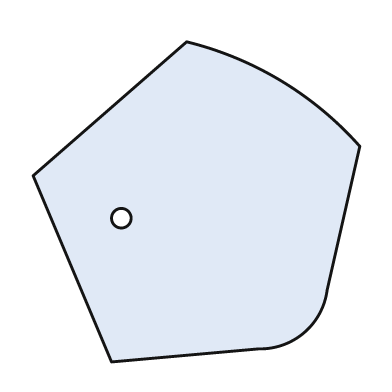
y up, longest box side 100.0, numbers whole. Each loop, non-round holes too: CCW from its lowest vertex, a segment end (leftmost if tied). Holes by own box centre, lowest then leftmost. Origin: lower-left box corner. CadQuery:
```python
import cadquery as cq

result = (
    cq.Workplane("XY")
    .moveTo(24.0, 0.0)
    .lineTo(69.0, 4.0)
    .threePointArc((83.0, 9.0), (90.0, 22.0))
    .lineTo(100.0, 66.0)
    .threePointArc((76.0, 86.0), (47.0, 98.0))
    .lineTo(0.0, 57.0)
    .close()
    .moveTo(27.0, 44.0)
    .circle(3.0)
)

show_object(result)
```